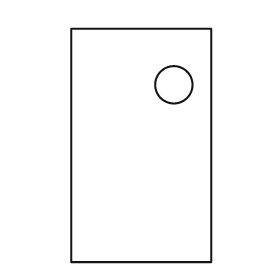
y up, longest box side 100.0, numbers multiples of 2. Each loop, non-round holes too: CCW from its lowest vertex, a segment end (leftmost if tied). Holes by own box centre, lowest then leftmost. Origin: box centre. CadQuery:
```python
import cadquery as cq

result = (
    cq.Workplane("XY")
    .moveTo(-30.0, -50.0)
    .lineTo(30.0, -50.0)
    .lineTo(30.0, 50.0)
    .lineTo(-30.0, 50.0)
    .close()
    .moveTo(14.0, 26.0)
    .circle(8.0)
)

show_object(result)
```